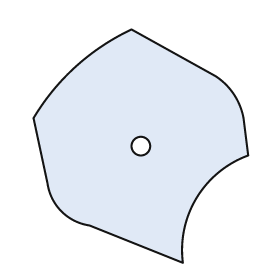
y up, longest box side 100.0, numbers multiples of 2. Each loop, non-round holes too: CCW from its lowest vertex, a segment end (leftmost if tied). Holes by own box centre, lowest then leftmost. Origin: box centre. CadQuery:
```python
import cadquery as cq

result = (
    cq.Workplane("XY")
    .moveTo(18.0, -50.0)
    .threePointArc((24.0, -22.0), (46.0, -4.0))
    .lineTo(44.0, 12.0)
    .threePointArc((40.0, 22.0), (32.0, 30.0))
    .lineTo(-4.0, 50.0)
    .threePointArc((-28.0, 34.0), (-46.0, 12.0))
    .lineTo(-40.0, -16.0)
    .threePointArc((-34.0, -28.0), (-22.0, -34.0))
    .close()
    .moveTo(0.0, 0.0)
    .circle(4.0)
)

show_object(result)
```